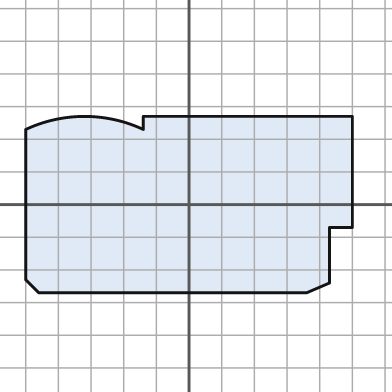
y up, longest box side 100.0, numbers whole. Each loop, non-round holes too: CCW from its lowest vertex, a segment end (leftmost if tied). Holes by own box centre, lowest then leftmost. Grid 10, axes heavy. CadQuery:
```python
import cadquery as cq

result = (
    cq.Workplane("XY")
    .moveTo(-46.0, -27.0)
    .lineTo(36.0, -27.0)
    .lineTo(43.0, -24.0)
    .lineTo(43.0, -7.0)
    .lineTo(50.0, -7.0)
    .lineTo(50.0, 27.0)
    .lineTo(-14.0, 27.0)
    .lineTo(-14.0, 23.0)
    .threePointArc((-32.0, 27.0), (-50.0, 23.0))
    .lineTo(-50.0, -23.0)
    .close()
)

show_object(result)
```